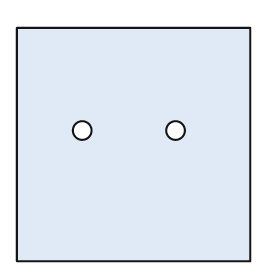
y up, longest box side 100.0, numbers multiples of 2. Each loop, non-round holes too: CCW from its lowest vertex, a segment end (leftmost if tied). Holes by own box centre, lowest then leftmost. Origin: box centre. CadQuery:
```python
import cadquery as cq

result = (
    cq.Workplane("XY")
    .moveTo(-50.0, -50.0)
    .lineTo(50.0, -50.0)
    .lineTo(50.0, 50.0)
    .lineTo(-50.0, 50.0)
    .close()
    .moveTo(-22.0, 6.0)
    .circle(4.0)
    .moveTo(18.0, 6.0)
    .circle(4.0)
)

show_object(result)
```